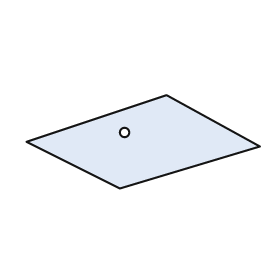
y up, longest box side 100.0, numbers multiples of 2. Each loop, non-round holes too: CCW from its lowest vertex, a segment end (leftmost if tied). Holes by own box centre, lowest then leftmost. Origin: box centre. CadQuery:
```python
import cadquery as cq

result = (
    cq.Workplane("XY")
    .moveTo(-10.0, -20.0)
    .lineTo(50.0, -2.0)
    .lineTo(10.0, 20.0)
    .lineTo(-50.0, 0.0)
    .close()
    .moveTo(-8.0, 4.0)
    .circle(2.0)
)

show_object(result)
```